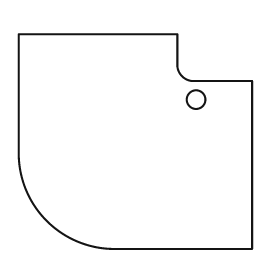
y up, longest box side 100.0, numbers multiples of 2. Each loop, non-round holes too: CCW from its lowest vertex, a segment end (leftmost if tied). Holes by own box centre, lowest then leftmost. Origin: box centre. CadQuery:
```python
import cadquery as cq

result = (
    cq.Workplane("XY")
    .moveTo(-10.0, -46.0)
    .lineTo(50.0, -46.0)
    .lineTo(50.0, 26.0)
    .lineTo(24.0, 26.0)
    .threePointArc((20.0, 28.0), (18.0, 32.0))
    .lineTo(18.0, 46.0)
    .lineTo(-50.0, 46.0)
    .lineTo(-50.0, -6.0)
    .threePointArc((-38.0, -34.0), (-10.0, -46.0))
    .close()
    .moveTo(26.0, 18.0)
    .circle(4.0)
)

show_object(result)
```